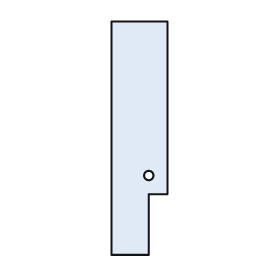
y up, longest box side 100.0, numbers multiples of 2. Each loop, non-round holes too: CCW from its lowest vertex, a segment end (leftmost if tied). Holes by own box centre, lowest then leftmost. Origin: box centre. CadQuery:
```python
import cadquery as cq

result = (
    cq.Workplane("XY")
    .moveTo(-12.0, -50.0)
    .lineTo(4.0, -50.0)
    .lineTo(4.0, -24.0)
    .lineTo(12.0, -24.0)
    .lineTo(12.0, 50.0)
    .lineTo(-12.0, 50.0)
    .close()
    .moveTo(4.0, -16.0)
    .circle(2.0)
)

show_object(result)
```